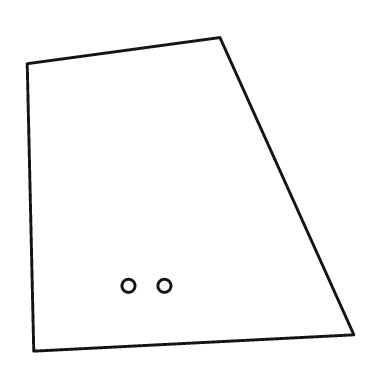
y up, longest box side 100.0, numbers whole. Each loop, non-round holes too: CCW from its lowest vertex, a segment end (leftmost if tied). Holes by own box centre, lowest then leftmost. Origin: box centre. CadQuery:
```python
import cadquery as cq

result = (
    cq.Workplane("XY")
    .moveTo(-48.0, -48.0)
    .lineTo(50.0, -43.0)
    .lineTo(9.0, 48.0)
    .lineTo(-50.0, 40.0)
    .close()
    .moveTo(-19.0, -28.0)
    .circle(2.0)
    .moveTo(-8.0, -28.0)
    .circle(2.0)
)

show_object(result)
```